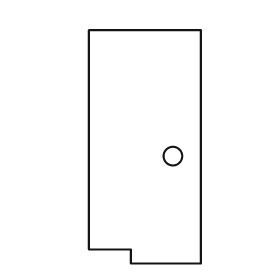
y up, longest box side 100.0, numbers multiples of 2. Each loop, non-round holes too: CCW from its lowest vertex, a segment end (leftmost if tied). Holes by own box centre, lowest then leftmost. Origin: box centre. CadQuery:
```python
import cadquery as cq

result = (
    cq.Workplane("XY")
    .moveTo(-6.0, -50.0)
    .lineTo(24.0, -50.0)
    .lineTo(24.0, 50.0)
    .lineTo(-24.0, 50.0)
    .lineTo(-24.0, -44.0)
    .lineTo(-6.0, -44.0)
    .close()
    .moveTo(12.0, -4.0)
    .circle(4.0)
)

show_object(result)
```